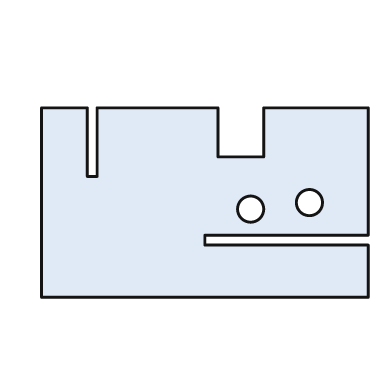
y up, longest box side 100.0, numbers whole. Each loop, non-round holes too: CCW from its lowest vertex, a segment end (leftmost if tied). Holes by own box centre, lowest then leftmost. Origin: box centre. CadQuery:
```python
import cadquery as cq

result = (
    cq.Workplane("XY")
    .moveTo(-50.0, -29.0)
    .lineTo(50.0, -29.0)
    .lineTo(50.0, -13.0)
    .lineTo(0.0, -13.0)
    .lineTo(0.0, -10.0)
    .lineTo(50.0, -10.0)
    .lineTo(50.0, 29.0)
    .lineTo(18.0, 29.0)
    .lineTo(18.0, 14.0)
    .lineTo(4.0, 14.0)
    .lineTo(4.0, 29.0)
    .lineTo(-33.0, 29.0)
    .lineTo(-33.0, 8.0)
    .lineTo(-36.0, 8.0)
    .lineTo(-36.0, 29.0)
    .lineTo(-50.0, 29.0)
    .close()
    .moveTo(14.0, -2.0)
    .circle(4.0)
    .moveTo(32.0, 0.0)
    .circle(4.0)
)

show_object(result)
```